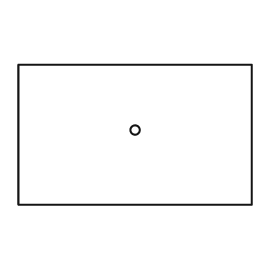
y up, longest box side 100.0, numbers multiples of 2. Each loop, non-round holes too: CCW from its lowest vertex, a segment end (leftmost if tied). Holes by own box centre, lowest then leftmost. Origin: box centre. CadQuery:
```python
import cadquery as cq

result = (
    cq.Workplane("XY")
    .moveTo(-50.0, -30.0)
    .lineTo(50.0, -30.0)
    .lineTo(50.0, 30.0)
    .lineTo(-50.0, 30.0)
    .close()
    .moveTo(0.0, 2.0)
    .circle(2.0)
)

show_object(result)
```